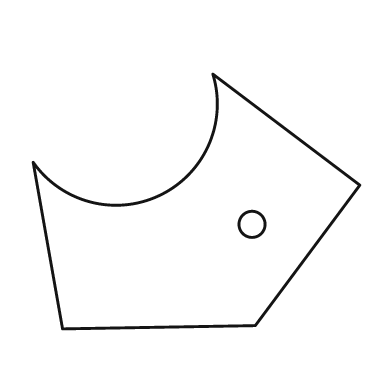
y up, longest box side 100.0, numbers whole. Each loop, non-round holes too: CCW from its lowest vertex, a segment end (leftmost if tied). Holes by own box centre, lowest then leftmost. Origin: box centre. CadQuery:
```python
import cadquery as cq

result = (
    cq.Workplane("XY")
    .moveTo(-41.0, -39.0)
    .lineTo(18.0, -38.0)
    .lineTo(50.0, 5.0)
    .lineTo(5.0, 39.0)
    .threePointArc((-11.0, 2.0), (-50.0, 12.0))
    .close()
    .moveTo(17.0, -7.0)
    .circle(4.0)
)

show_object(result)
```